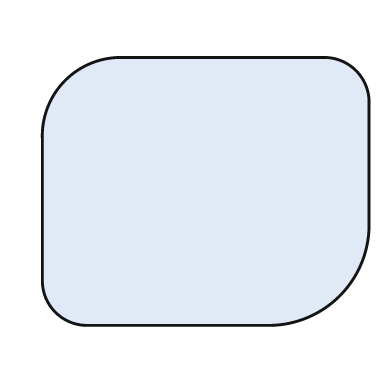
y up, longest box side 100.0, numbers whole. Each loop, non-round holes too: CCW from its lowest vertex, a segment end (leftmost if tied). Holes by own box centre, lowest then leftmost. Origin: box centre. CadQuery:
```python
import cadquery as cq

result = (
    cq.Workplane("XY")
    .moveTo(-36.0, -41.0)
    .lineTo(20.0, -41.0)
    .threePointArc((41.0, -32.0), (50.0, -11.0))
    .lineTo(50.0, 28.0)
    .threePointArc((46.0, 37.0), (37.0, 41.0))
    .lineTo(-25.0, 41.0)
    .threePointArc((-43.0, 34.0), (-50.0, 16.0))
    .lineTo(-50.0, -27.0)
    .threePointArc((-46.0, -37.0), (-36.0, -41.0))
    .close()
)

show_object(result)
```